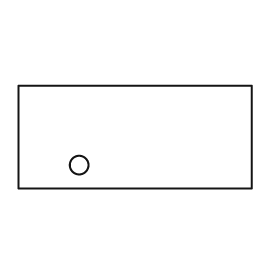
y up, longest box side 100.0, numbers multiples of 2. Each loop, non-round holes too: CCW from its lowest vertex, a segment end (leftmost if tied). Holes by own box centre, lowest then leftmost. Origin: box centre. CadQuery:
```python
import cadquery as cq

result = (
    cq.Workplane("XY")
    .moveTo(-50.0, -22.0)
    .lineTo(50.0, -22.0)
    .lineTo(50.0, 22.0)
    .lineTo(-50.0, 22.0)
    .close()
    .moveTo(-24.0, -12.0)
    .circle(4.0)
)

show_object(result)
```